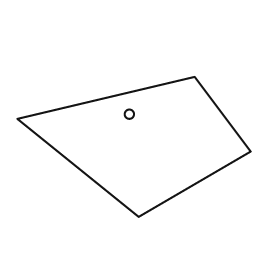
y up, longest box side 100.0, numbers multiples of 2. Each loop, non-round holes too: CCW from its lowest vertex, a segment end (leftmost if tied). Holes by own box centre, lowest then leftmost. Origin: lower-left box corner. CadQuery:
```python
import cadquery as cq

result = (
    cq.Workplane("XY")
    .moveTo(52.0, 0.0)
    .lineTo(100.0, 28.0)
    .lineTo(76.0, 60.0)
    .lineTo(0.0, 42.0)
    .close()
    .moveTo(48.0, 44.0)
    .circle(2.0)
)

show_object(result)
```